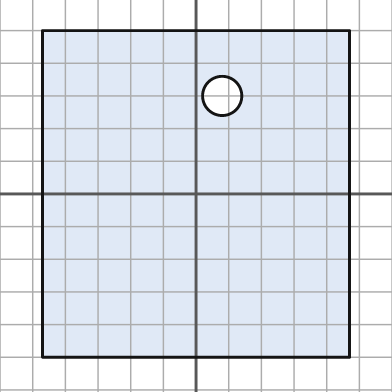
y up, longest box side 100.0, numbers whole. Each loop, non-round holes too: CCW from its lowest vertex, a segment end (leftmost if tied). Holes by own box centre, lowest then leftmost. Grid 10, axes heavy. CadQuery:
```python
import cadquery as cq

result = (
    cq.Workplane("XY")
    .moveTo(-47.0, -50.0)
    .lineTo(47.0, -50.0)
    .lineTo(47.0, 50.0)
    .lineTo(-47.0, 50.0)
    .close()
    .moveTo(8.0, 30.0)
    .circle(6.0)
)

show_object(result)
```